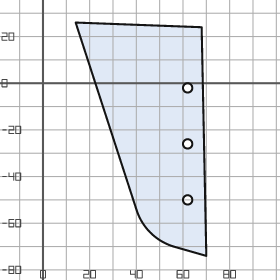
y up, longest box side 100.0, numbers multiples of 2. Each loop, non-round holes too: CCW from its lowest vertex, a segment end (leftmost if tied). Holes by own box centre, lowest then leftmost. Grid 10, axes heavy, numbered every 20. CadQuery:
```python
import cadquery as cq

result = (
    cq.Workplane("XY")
    .moveTo(70.0, -74.0)
    .lineTo(68.0, 24.0)
    .lineTo(14.0, 26.0)
    .lineTo(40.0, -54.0)
    .threePointArc((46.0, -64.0), (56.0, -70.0))
    .close()
    .moveTo(62.0, -50.0)
    .circle(2.0)
    .moveTo(62.0, -26.0)
    .circle(2.0)
    .moveTo(62.0, -2.0)
    .circle(2.0)
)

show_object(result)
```